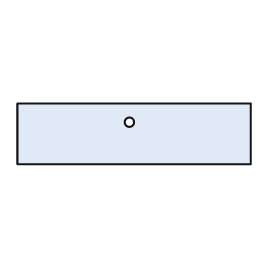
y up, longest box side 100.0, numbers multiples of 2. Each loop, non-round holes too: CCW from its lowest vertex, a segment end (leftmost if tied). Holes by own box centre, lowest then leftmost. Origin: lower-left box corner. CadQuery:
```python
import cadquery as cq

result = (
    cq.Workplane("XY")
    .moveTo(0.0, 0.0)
    .lineTo(100.0, 0.0)
    .lineTo(100.0, 26.0)
    .lineTo(0.0, 26.0)
    .close()
    .moveTo(48.0, 18.0)
    .circle(2.0)
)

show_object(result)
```